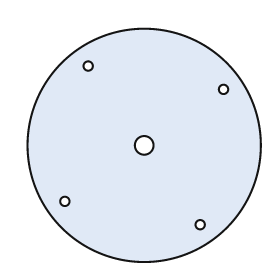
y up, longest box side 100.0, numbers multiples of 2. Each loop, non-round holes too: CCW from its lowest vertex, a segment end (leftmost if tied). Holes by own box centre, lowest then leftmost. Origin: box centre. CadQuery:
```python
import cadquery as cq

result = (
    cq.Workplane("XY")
    .moveTo(0.0, 0.0)
    .circle(50.0)
    .moveTo(24.0, -34.0)
    .circle(2.0)
    .moveTo(-34.0, -24.0)
    .circle(2.0)
    .moveTo(0.0, 0.0)
    .circle(4.0)
    .moveTo(34.0, 24.0)
    .circle(2.0)
    .moveTo(-24.0, 34.0)
    .circle(2.0)
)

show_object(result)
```